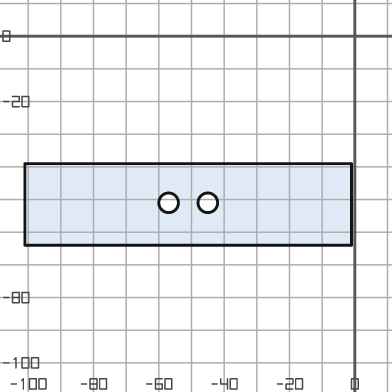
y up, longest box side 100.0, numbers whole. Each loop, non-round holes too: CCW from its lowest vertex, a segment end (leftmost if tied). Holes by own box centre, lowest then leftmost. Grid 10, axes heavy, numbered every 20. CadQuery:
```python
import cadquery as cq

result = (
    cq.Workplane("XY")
    .moveTo(-101.0, -64.0)
    .lineTo(-1.0, -64.0)
    .lineTo(-1.0, -39.0)
    .lineTo(-101.0, -39.0)
    .close()
    .moveTo(-57.0, -51.0)
    .circle(3.0)
    .moveTo(-45.0, -51.0)
    .circle(3.0)
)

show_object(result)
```